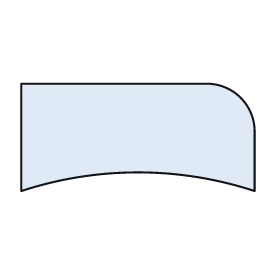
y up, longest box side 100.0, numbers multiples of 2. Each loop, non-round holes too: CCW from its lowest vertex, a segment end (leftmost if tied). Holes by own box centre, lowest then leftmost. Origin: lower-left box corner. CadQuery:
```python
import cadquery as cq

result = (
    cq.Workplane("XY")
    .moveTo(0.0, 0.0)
    .threePointArc((50.0, 8.0), (100.0, 0.0))
    .lineTo(100.0, 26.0)
    .threePointArc((94.0, 40.0), (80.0, 46.0))
    .lineTo(0.0, 46.0)
    .close()
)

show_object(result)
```